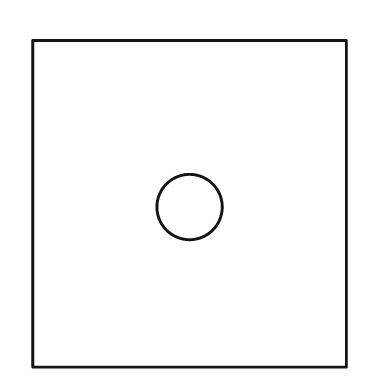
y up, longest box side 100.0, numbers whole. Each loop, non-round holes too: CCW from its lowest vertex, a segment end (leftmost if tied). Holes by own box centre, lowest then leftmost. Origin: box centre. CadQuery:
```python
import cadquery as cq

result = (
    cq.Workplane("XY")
    .moveTo(-48.0, -50.0)
    .lineTo(48.0, -50.0)
    .lineTo(48.0, 50.0)
    .lineTo(-48.0, 50.0)
    .close()
    .moveTo(0.0, -1.0)
    .circle(10.0)
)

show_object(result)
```